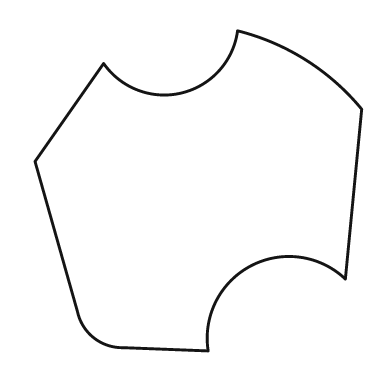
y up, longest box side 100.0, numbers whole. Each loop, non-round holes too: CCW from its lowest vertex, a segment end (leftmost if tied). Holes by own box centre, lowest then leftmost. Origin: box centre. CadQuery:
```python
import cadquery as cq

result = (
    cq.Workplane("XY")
    .moveTo(3.0, -49.0)
    .threePointArc((16.0, -23.0), (45.0, -27.0))
    .lineTo(50.0, 25.0)
    .threePointArc((33.0, 40.0), (12.0, 49.0))
    .threePointArc((-5.0, 30.0), (-29.0, 39.0))
    .lineTo(-50.0, 9.0)
    .lineTo(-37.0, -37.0)
    .threePointArc((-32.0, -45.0), (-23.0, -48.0))
    .close()
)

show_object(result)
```